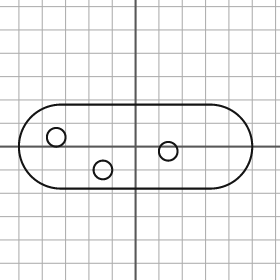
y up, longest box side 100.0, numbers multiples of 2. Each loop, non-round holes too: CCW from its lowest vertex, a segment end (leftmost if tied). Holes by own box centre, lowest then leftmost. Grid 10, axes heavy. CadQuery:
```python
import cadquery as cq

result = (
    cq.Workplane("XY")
    .moveTo(-32.0, -18.0)
    .lineTo(32.0, -18.0)
    .threePointArc((50.0, 0.0), (32.0, 18.0))
    .lineTo(-32.0, 18.0)
    .threePointArc((-50.0, 0.0), (-32.0, -18.0))
    .close()
    .moveTo(-14.0, -10.0)
    .circle(4.0)
    .moveTo(14.0, -2.0)
    .circle(4.0)
    .moveTo(-34.0, 4.0)
    .circle(4.0)
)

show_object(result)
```